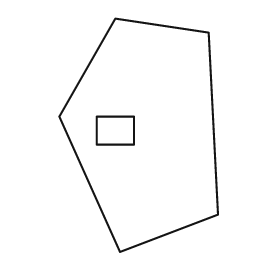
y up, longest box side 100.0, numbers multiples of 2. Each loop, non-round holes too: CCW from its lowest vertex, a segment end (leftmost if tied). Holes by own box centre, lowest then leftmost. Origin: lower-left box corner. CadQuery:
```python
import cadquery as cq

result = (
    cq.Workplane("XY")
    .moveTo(26.0, 0.0)
    .lineTo(68.0, 16.0)
    .lineTo(64.0, 94.0)
    .lineTo(24.0, 100.0)
    .lineTo(0.0, 58.0)
    .close()
    .moveTo(16.0, 46.0)
    .lineTo(32.0, 46.0)
    .lineTo(32.0, 58.0)
    .lineTo(16.0, 58.0)
    .close()
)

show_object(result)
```